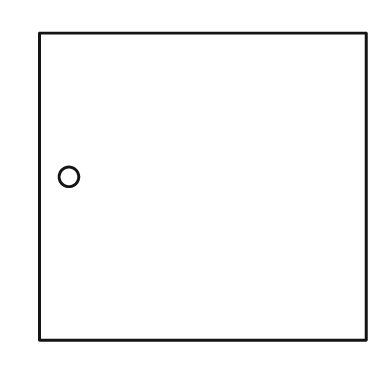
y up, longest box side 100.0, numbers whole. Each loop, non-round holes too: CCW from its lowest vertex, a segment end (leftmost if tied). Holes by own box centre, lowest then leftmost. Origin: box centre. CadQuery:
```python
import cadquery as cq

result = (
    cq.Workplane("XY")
    .moveTo(-50.0, -47.0)
    .lineTo(50.0, -47.0)
    .lineTo(50.0, 47.0)
    .lineTo(-50.0, 47.0)
    .close()
    .moveTo(-41.0, 3.0)
    .circle(3.0)
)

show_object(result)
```